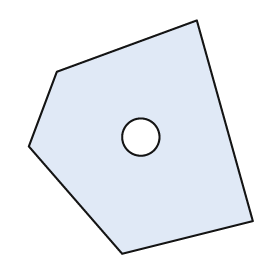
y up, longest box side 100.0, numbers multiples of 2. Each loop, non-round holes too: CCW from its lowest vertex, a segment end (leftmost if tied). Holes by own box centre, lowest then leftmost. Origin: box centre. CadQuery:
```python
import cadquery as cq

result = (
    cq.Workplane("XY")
    .moveTo(-8.0, -50.0)
    .lineTo(48.0, -36.0)
    .lineTo(24.0, 50.0)
    .lineTo(-36.0, 28.0)
    .lineTo(-48.0, -4.0)
    .close()
    .moveTo(0.0, 0.0)
    .circle(8.0)
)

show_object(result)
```